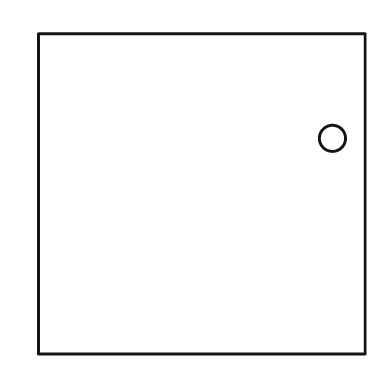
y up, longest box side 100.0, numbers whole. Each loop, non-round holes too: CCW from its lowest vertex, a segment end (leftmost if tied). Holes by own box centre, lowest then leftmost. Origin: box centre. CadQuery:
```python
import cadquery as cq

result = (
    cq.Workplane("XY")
    .moveTo(-50.0, -49.0)
    .lineTo(50.0, -49.0)
    .lineTo(50.0, 49.0)
    .lineTo(-50.0, 49.0)
    .close()
    .moveTo(40.0, 17.0)
    .circle(4.0)
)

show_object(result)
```